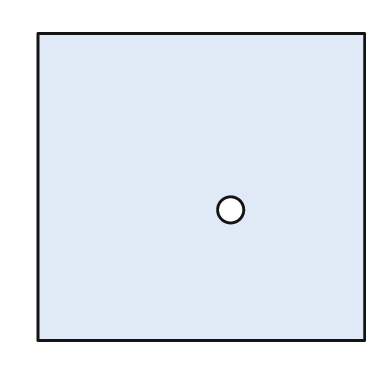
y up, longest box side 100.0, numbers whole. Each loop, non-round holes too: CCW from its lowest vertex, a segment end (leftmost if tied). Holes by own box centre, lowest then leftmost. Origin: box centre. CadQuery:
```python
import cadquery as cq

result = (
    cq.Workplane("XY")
    .moveTo(-50.0, -47.0)
    .lineTo(50.0, -47.0)
    .lineTo(50.0, 47.0)
    .lineTo(-50.0, 47.0)
    .close()
    .moveTo(9.0, -7.0)
    .circle(4.0)
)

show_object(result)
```